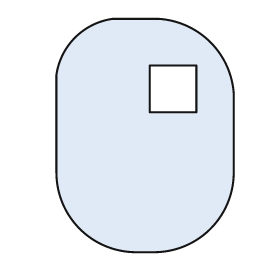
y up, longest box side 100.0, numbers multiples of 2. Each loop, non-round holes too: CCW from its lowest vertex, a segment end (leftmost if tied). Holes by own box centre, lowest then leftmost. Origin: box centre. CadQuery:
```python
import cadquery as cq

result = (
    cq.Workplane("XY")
    .moveTo(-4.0, -50.0)
    .lineTo(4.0, -50.0)
    .threePointArc((28.0, -40.0), (38.0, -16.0))
    .lineTo(38.0, 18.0)
    .threePointArc((28.0, 40.0), (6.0, 50.0))
    .lineTo(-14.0, 50.0)
    .threePointArc((-30.0, 42.0), (-38.0, 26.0))
    .lineTo(-38.0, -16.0)
    .threePointArc((-28.0, -40.0), (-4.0, -50.0))
    .close()
    .moveTo(2.0, 10.0)
    .lineTo(22.0, 10.0)
    .lineTo(22.0, 30.0)
    .lineTo(2.0, 30.0)
    .close()
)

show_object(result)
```